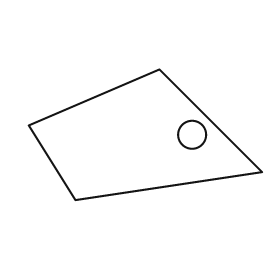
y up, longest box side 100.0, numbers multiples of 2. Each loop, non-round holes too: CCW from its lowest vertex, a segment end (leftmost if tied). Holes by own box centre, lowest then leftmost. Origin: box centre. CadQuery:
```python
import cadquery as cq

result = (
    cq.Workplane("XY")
    .moveTo(-30.0, -28.0)
    .lineTo(50.0, -16.0)
    .lineTo(6.0, 28.0)
    .lineTo(-50.0, 4.0)
    .close()
    .moveTo(20.0, 0.0)
    .circle(6.0)
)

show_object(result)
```